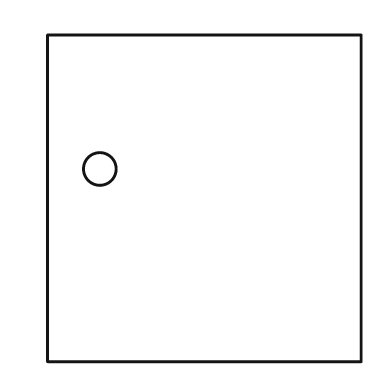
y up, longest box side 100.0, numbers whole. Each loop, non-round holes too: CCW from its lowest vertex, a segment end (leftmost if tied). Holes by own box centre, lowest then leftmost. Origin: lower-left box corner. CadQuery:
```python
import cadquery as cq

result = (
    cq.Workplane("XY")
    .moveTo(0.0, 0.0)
    .lineTo(96.0, 0.0)
    .lineTo(96.0, 100.0)
    .lineTo(0.0, 100.0)
    .close()
    .moveTo(16.0, 59.0)
    .circle(5.0)
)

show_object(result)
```